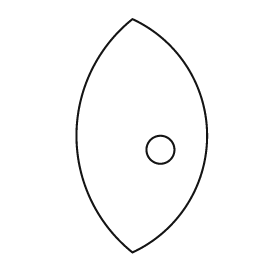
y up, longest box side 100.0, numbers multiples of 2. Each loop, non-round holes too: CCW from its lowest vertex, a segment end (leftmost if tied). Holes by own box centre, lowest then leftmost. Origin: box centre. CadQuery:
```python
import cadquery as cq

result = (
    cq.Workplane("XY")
    .moveTo(-4.0, -50.0)
    .threePointArc((28.0, 0.0), (-4.0, 50.0))
    .threePointArc((-28.0, 0.0), (-4.0, -50.0))
    .close()
    .moveTo(8.0, -6.0)
    .circle(6.0)
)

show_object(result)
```